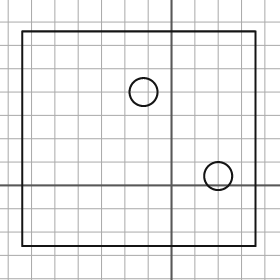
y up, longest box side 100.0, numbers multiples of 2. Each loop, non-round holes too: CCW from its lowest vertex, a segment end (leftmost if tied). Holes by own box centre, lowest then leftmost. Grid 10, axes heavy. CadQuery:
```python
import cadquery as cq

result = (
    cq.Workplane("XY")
    .moveTo(-64.0, -26.0)
    .lineTo(36.0, -26.0)
    .lineTo(36.0, 66.0)
    .lineTo(-64.0, 66.0)
    .close()
    .moveTo(20.0, 4.0)
    .circle(6.0)
    .moveTo(-12.0, 40.0)
    .circle(6.0)
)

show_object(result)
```